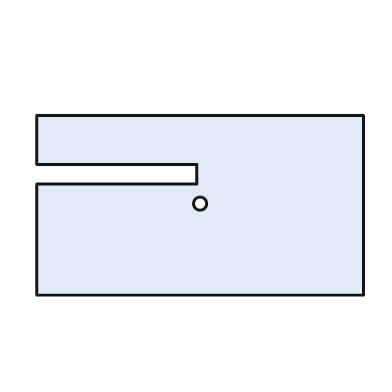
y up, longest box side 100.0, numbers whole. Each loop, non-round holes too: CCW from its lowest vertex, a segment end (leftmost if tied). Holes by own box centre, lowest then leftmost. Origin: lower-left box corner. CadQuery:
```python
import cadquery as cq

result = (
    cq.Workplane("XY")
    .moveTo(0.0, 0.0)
    .lineTo(100.0, 0.0)
    .lineTo(100.0, 55.0)
    .lineTo(0.0, 55.0)
    .lineTo(0.0, 40.0)
    .lineTo(49.0, 40.0)
    .lineTo(49.0, 34.0)
    .lineTo(0.0, 34.0)
    .close()
    .moveTo(50.0, 28.0)
    .circle(2.0)
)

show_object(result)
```